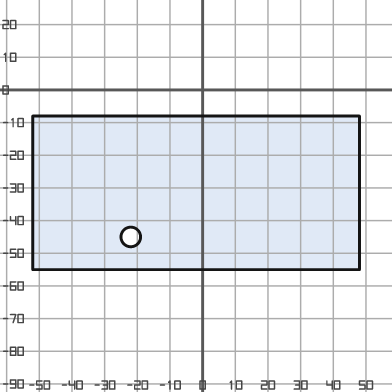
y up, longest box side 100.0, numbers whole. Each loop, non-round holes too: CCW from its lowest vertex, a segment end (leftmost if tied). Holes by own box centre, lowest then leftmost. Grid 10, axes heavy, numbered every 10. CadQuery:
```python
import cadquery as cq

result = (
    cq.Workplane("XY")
    .moveTo(-52.0, -55.0)
    .lineTo(48.0, -55.0)
    .lineTo(48.0, -8.0)
    .lineTo(-52.0, -8.0)
    .close()
    .moveTo(-22.0, -45.0)
    .circle(3.0)
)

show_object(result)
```